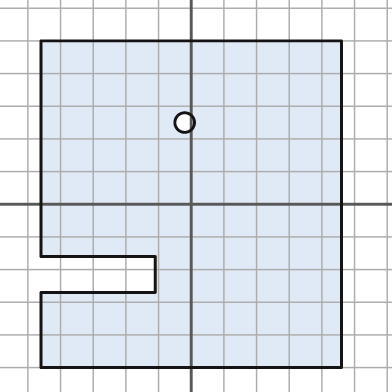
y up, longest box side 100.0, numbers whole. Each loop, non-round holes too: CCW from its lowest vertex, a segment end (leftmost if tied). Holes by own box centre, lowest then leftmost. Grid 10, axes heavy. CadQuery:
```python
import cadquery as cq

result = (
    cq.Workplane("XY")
    .moveTo(-46.0, -50.0)
    .lineTo(46.0, -50.0)
    .lineTo(46.0, 50.0)
    .lineTo(-46.0, 50.0)
    .lineTo(-46.0, -16.0)
    .lineTo(-11.0, -16.0)
    .lineTo(-11.0, -27.0)
    .lineTo(-46.0, -27.0)
    .close()
    .moveTo(-2.0, 25.0)
    .circle(3.0)
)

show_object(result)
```